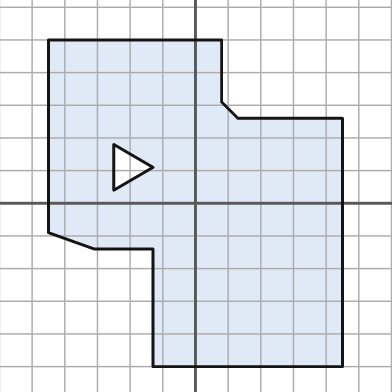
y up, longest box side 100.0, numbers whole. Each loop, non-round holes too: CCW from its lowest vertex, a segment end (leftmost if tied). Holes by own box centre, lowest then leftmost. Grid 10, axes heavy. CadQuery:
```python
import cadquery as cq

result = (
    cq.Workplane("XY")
    .moveTo(-13.0, -50.0)
    .lineTo(45.0, -50.0)
    .lineTo(45.0, 26.0)
    .lineTo(13.0, 26.0)
    .lineTo(8.0, 31.0)
    .lineTo(8.0, 50.0)
    .lineTo(-45.0, 50.0)
    .lineTo(-45.0, -9.0)
    .lineTo(-31.0, -14.0)
    .lineTo(-13.0, -14.0)
    .close()
    .moveTo(-25.0, 4.0)
    .lineTo(-13.0, 11.0)
    .lineTo(-25.0, 18.0)
    .close()
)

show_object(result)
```